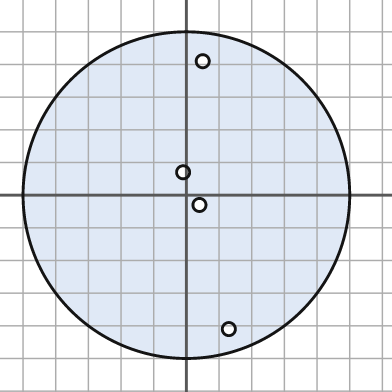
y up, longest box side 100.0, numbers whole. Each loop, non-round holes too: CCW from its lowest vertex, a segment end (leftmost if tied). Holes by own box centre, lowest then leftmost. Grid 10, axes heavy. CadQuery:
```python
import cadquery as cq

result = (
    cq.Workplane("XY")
    .moveTo(0.0, 0.0)
    .circle(50.0)
    .moveTo(13.0, -41.0)
    .circle(2.0)
    .moveTo(4.0, -3.0)
    .circle(2.0)
    .moveTo(-1.0, 7.0)
    .circle(2.0)
    .moveTo(5.0, 41.0)
    .circle(2.0)
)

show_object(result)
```